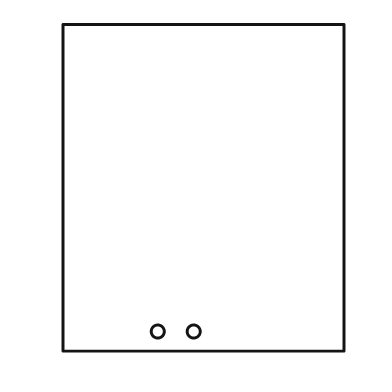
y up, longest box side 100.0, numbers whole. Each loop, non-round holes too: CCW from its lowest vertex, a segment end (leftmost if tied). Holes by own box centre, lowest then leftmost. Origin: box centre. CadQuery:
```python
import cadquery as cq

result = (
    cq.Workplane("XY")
    .moveTo(-43.0, -50.0)
    .lineTo(43.0, -50.0)
    .lineTo(43.0, 50.0)
    .lineTo(-43.0, 50.0)
    .close()
    .moveTo(-14.0, -44.0)
    .circle(2.0)
    .moveTo(-3.0, -44.0)
    .circle(2.0)
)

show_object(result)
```